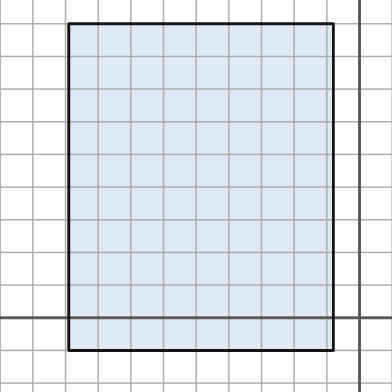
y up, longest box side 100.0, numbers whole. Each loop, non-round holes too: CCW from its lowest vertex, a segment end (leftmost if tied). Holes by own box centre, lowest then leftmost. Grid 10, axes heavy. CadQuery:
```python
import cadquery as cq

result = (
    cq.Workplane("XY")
    .moveTo(-89.0, -10.0)
    .lineTo(-8.0, -10.0)
    .lineTo(-8.0, 90.0)
    .lineTo(-89.0, 90.0)
    .close()
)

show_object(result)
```